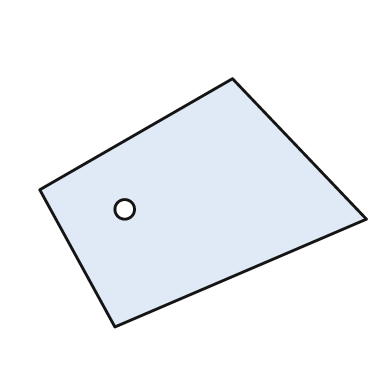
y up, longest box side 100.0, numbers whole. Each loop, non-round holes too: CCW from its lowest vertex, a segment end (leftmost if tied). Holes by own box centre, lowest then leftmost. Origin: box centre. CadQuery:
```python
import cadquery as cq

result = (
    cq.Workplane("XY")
    .moveTo(-27.0, -38.0)
    .lineTo(50.0, -5.0)
    .lineTo(9.0, 38.0)
    .lineTo(-50.0, 4.0)
    .close()
    .moveTo(-24.0, -2.0)
    .circle(3.0)
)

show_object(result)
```